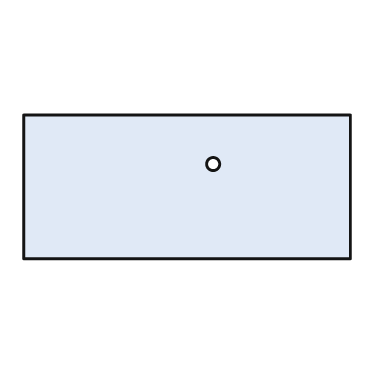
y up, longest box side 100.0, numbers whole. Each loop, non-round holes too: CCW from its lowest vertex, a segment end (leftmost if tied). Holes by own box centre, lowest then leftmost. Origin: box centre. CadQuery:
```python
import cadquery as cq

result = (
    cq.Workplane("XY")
    .moveTo(-50.0, -22.0)
    .lineTo(50.0, -22.0)
    .lineTo(50.0, 22.0)
    .lineTo(-50.0, 22.0)
    .close()
    .moveTo(8.0, 7.0)
    .circle(2.0)
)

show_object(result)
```